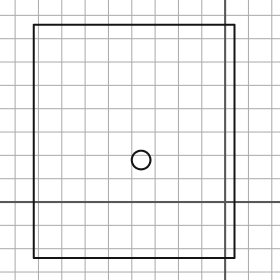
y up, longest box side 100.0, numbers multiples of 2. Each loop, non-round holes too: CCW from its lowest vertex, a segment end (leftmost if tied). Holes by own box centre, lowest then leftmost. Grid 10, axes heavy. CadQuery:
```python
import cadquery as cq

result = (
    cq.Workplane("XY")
    .moveTo(-82.0, -24.0)
    .lineTo(4.0, -24.0)
    .lineTo(4.0, 76.0)
    .lineTo(-82.0, 76.0)
    .close()
    .moveTo(-36.0, 18.0)
    .circle(4.0)
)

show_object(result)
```